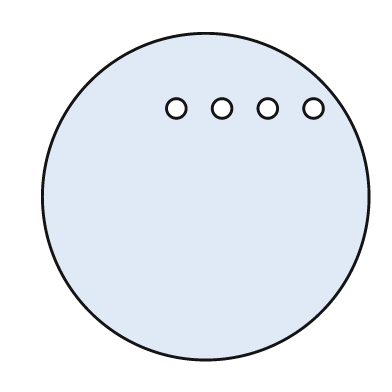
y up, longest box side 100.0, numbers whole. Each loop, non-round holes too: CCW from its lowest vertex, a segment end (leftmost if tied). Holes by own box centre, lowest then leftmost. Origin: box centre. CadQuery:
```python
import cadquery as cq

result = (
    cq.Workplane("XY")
    .moveTo(0.0, 0.0)
    .circle(50.0)
    .moveTo(-9.0, 27.0)
    .circle(3.0)
    .moveTo(5.0, 27.0)
    .circle(3.0)
    .moveTo(19.0, 27.0)
    .circle(3.0)
    .moveTo(33.0, 27.0)
    .circle(3.0)
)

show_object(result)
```